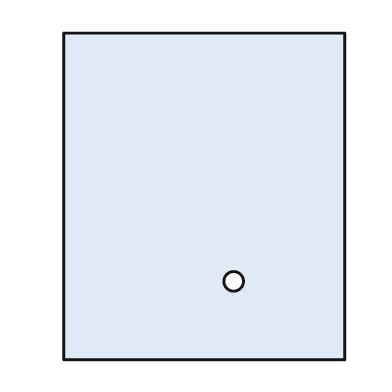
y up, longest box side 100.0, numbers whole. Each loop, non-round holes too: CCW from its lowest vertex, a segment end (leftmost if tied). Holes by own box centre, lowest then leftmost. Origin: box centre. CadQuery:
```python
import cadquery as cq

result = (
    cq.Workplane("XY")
    .moveTo(-43.0, -50.0)
    .lineTo(43.0, -50.0)
    .lineTo(43.0, 50.0)
    .lineTo(-43.0, 50.0)
    .close()
    .moveTo(9.0, -26.0)
    .circle(3.0)
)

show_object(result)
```